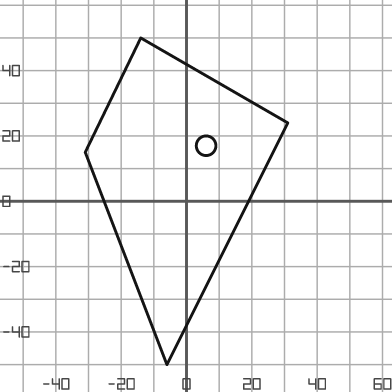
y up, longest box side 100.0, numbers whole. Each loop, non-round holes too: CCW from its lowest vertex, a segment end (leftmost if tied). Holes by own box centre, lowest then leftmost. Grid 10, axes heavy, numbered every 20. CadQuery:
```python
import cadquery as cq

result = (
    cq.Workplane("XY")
    .moveTo(-6.0, -50.0)
    .lineTo(31.0, 24.0)
    .lineTo(-14.0, 50.0)
    .lineTo(-31.0, 15.0)
    .close()
    .moveTo(6.0, 17.0)
    .circle(3.0)
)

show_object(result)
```